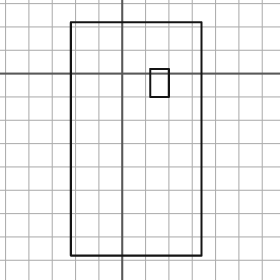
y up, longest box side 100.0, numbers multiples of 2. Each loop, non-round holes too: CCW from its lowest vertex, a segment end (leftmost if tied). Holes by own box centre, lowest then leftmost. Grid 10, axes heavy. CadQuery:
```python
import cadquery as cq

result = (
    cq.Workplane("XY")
    .moveTo(-22.0, -78.0)
    .lineTo(34.0, -78.0)
    .lineTo(34.0, 22.0)
    .lineTo(-22.0, 22.0)
    .close()
    .moveTo(12.0, -10.0)
    .lineTo(20.0, -10.0)
    .lineTo(20.0, 2.0)
    .lineTo(12.0, 2.0)
    .close()
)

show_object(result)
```